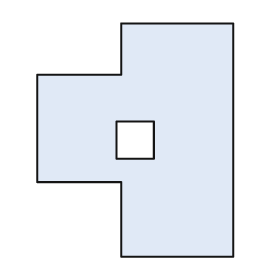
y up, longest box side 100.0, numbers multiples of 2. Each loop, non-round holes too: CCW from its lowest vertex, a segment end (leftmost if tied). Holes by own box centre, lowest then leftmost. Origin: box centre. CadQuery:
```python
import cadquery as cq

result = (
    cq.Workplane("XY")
    .moveTo(-6.0, -50.0)
    .lineTo(42.0, -50.0)
    .lineTo(42.0, 50.0)
    .lineTo(-6.0, 50.0)
    .lineTo(-6.0, 28.0)
    .lineTo(-42.0, 28.0)
    .lineTo(-42.0, -18.0)
    .lineTo(-6.0, -18.0)
    .close()
    .moveTo(-8.0, -8.0)
    .lineTo(8.0, -8.0)
    .lineTo(8.0, 8.0)
    .lineTo(-8.0, 8.0)
    .close()
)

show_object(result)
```